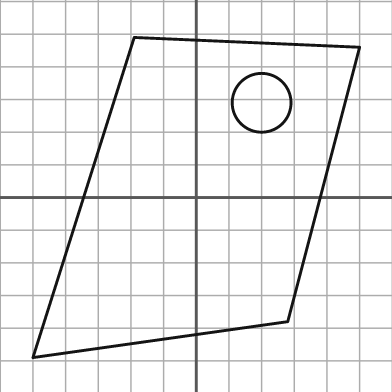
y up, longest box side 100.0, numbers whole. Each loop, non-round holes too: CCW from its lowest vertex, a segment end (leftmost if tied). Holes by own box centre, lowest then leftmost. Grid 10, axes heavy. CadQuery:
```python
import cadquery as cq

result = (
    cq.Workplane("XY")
    .moveTo(-50.0, -49.0)
    .lineTo(28.0, -38.0)
    .lineTo(50.0, 46.0)
    .lineTo(-19.0, 49.0)
    .close()
    .moveTo(20.0, 29.0)
    .circle(9.0)
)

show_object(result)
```